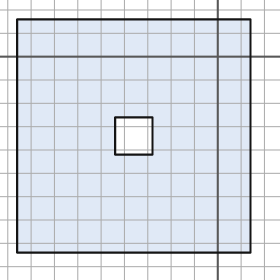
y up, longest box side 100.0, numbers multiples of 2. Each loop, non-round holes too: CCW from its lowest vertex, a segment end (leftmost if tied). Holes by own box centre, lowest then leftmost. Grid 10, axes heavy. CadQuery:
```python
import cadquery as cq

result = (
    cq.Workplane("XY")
    .moveTo(-86.0, -84.0)
    .lineTo(14.0, -84.0)
    .lineTo(14.0, 16.0)
    .lineTo(-86.0, 16.0)
    .close()
    .moveTo(-44.0, -42.0)
    .lineTo(-28.0, -42.0)
    .lineTo(-28.0, -26.0)
    .lineTo(-44.0, -26.0)
    .close()
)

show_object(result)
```